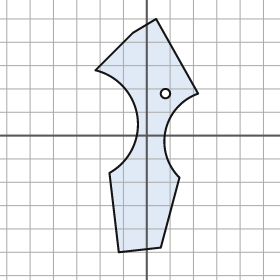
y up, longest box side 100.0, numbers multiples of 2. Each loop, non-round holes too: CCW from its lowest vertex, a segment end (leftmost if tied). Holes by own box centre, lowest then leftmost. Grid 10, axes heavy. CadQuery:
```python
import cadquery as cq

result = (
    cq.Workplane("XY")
    .moveTo(-12.0, -50.0)
    .lineTo(6.0, -48.0)
    .lineTo(14.0, -18.0)
    .threePointArc((8.0, 2.0), (22.0, 18.0))
    .lineTo(4.0, 50.0)
    .lineTo(-6.0, 44.0)
    .lineTo(-22.0, 28.0)
    .threePointArc((-4.0, 8.0), (-16.0, -16.0))
    .close()
    .moveTo(8.0, 18.0)
    .circle(2.0)
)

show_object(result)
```